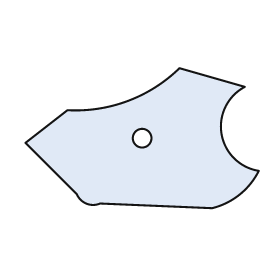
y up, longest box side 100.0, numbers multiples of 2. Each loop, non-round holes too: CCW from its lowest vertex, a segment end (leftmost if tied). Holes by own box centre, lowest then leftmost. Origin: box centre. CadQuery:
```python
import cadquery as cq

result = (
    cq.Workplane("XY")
    .moveTo(30.0, -30.0)
    .threePointArc((42.0, -24.0), (50.0, -14.0))
    .threePointArc((34.0, 2.0), (44.0, 22.0))
    .lineTo(16.0, 30.0)
    .threePointArc((-6.0, 16.0), (-32.0, 12.0))
    .lineTo(-50.0, -2.0)
    .lineTo(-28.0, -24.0)
    .threePointArc((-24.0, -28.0), (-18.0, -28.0))
    .close()
    .moveTo(0.0, 0.0)
    .circle(4.0)
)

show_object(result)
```